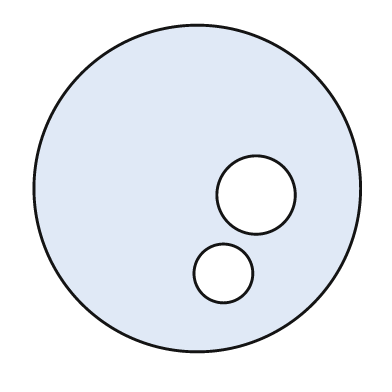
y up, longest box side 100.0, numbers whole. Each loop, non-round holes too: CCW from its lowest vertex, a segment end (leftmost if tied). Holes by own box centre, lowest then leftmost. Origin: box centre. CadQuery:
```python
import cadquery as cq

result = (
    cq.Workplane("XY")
    .moveTo(0.0, 0.0)
    .circle(50.0)
    .moveTo(8.0, -26.0)
    .circle(9.0)
    .moveTo(18.0, -2.0)
    .circle(12.0)
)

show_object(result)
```